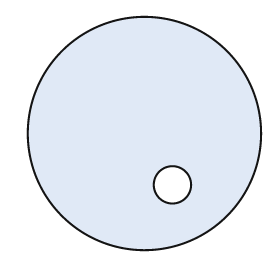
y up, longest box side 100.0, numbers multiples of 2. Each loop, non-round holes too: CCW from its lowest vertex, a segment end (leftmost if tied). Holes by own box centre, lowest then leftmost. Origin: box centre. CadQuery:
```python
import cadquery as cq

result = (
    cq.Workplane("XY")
    .moveTo(0.0, 0.0)
    .circle(50.0)
    .moveTo(12.0, -22.0)
    .circle(8.0)
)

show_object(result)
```